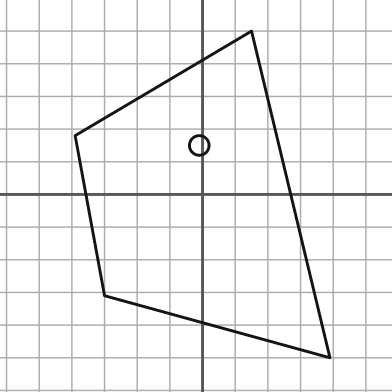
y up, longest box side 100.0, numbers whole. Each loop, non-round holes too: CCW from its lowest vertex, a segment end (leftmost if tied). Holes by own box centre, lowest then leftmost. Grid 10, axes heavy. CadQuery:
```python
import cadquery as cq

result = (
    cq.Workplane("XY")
    .moveTo(39.0, -50.0)
    .lineTo(15.0, 50.0)
    .lineTo(-39.0, 18.0)
    .lineTo(-30.0, -31.0)
    .close()
    .moveTo(-1.0, 15.0)
    .circle(3.0)
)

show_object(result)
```